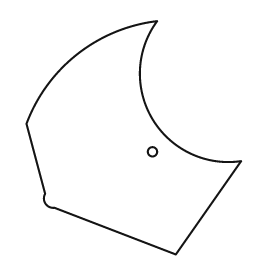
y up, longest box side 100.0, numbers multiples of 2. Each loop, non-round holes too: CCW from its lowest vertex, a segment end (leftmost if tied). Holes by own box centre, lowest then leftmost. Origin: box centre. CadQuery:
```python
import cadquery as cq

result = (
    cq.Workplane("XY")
    .moveTo(18.0, -50.0)
    .lineTo(46.0, -10.0)
    .threePointArc((8.0, 8.0), (10.0, 50.0))
    .threePointArc((-24.0, 36.0), (-46.0, 6.0))
    .lineTo(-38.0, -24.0)
    .threePointArc((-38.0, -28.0), (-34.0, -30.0))
    .close()
    .moveTo(8.0, -6.0)
    .circle(2.0)
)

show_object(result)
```